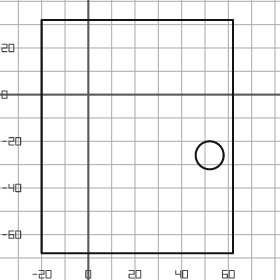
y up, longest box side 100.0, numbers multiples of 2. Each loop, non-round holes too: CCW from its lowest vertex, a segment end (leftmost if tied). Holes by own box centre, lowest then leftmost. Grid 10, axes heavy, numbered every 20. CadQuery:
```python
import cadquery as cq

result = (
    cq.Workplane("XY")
    .moveTo(-20.0, -68.0)
    .lineTo(62.0, -68.0)
    .lineTo(62.0, 32.0)
    .lineTo(-20.0, 32.0)
    .close()
    .moveTo(52.0, -26.0)
    .circle(6.0)
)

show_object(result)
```